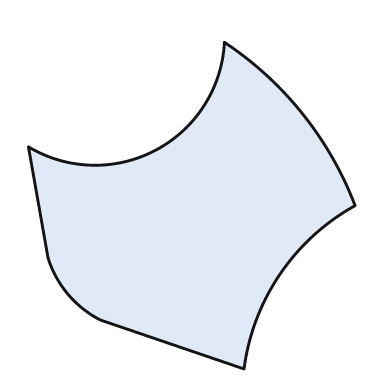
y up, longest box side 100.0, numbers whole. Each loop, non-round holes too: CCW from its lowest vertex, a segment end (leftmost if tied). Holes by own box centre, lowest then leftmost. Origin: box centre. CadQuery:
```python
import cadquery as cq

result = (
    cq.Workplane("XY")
    .moveTo(16.0, -50.0)
    .threePointArc((27.0, -21.0), (50.0, 0.0))
    .threePointArc((34.0, 28.0), (10.0, 50.0))
    .threePointArc((-11.0, 17.0), (-50.0, 18.0))
    .lineTo(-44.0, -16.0)
    .threePointArc((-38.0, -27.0), (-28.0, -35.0))
    .close()
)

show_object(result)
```